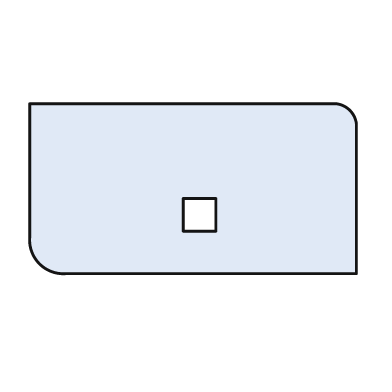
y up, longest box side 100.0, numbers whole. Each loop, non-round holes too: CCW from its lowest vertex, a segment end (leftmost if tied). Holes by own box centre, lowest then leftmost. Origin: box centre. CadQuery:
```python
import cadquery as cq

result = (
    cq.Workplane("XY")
    .moveTo(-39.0, -26.0)
    .lineTo(50.0, -26.0)
    .lineTo(50.0, 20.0)
    .threePointArc((48.0, 24.0), (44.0, 26.0))
    .lineTo(-50.0, 26.0)
    .lineTo(-50.0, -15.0)
    .threePointArc((-47.0, -23.0), (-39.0, -26.0))
    .close()
    .moveTo(-3.0, -13.0)
    .lineTo(7.0, -13.0)
    .lineTo(7.0, -3.0)
    .lineTo(-3.0, -3.0)
    .close()
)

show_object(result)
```